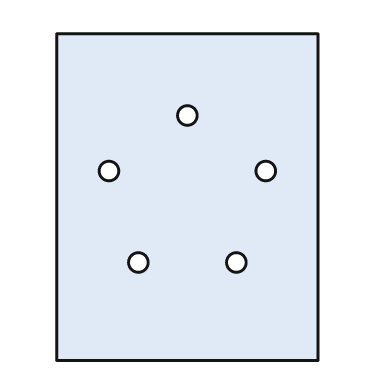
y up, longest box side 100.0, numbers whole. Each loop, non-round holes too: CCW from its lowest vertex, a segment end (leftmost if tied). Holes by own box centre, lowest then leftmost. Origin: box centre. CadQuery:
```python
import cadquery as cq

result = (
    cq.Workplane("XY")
    .moveTo(-40.0, -50.0)
    .lineTo(40.0, -50.0)
    .lineTo(40.0, 50.0)
    .lineTo(-40.0, 50.0)
    .close()
    .moveTo(-15.0, -20.0)
    .circle(3.0)
    .moveTo(15.0, -20.0)
    .circle(3.0)
    .moveTo(-24.0, 8.0)
    .circle(3.0)
    .moveTo(24.0, 8.0)
    .circle(3.0)
    .moveTo(0.0, 25.0)
    .circle(3.0)
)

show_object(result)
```